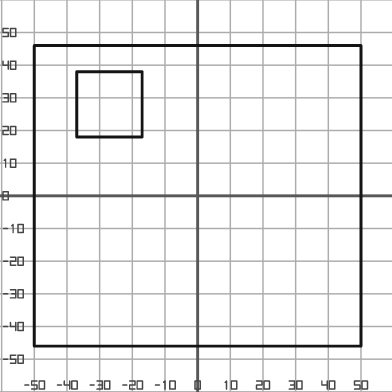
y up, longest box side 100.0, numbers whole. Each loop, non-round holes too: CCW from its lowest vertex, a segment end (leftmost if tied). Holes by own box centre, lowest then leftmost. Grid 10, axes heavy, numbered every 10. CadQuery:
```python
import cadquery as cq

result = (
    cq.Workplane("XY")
    .moveTo(-50.0, -46.0)
    .lineTo(50.0, -46.0)
    .lineTo(50.0, 46.0)
    .lineTo(-50.0, 46.0)
    .close()
    .moveTo(-37.0, 18.0)
    .lineTo(-17.0, 18.0)
    .lineTo(-17.0, 38.0)
    .lineTo(-37.0, 38.0)
    .close()
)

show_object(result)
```